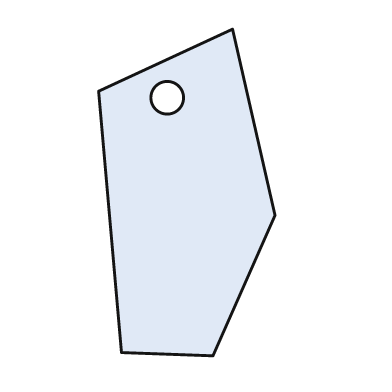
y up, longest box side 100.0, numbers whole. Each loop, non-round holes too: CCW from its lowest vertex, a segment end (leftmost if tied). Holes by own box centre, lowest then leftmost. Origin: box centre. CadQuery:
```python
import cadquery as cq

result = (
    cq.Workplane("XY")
    .moveTo(8.0, -50.0)
    .lineTo(27.0, -7.0)
    .lineTo(14.0, 50.0)
    .lineTo(-27.0, 31.0)
    .lineTo(-20.0, -49.0)
    .close()
    .moveTo(-6.0, 29.0)
    .circle(5.0)
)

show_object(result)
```